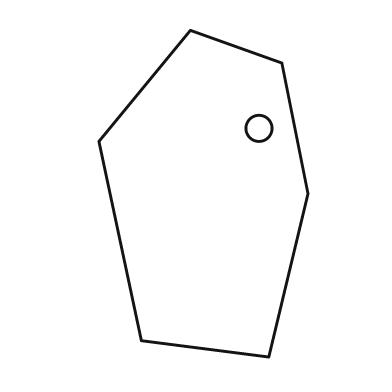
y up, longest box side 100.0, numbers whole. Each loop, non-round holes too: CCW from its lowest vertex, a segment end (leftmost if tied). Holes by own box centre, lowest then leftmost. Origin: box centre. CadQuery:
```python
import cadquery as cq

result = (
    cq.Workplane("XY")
    .moveTo(20.0, -50.0)
    .lineTo(32.0, 0.0)
    .lineTo(24.0, 40.0)
    .lineTo(-4.0, 50.0)
    .lineTo(-32.0, 16.0)
    .lineTo(-19.0, -45.0)
    .close()
    .moveTo(17.0, 20.0)
    .circle(4.0)
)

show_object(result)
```